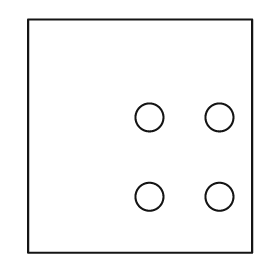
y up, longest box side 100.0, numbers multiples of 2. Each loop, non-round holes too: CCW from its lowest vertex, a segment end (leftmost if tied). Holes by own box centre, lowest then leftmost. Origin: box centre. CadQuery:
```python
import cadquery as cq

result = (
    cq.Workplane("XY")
    .moveTo(-48.0, -50.0)
    .lineTo(48.0, -50.0)
    .lineTo(48.0, 50.0)
    .lineTo(-48.0, 50.0)
    .close()
    .moveTo(4.0, -26.0)
    .circle(6.0)
    .moveTo(34.0, -26.0)
    .circle(6.0)
    .moveTo(4.0, 8.0)
    .circle(6.0)
    .moveTo(34.0, 8.0)
    .circle(6.0)
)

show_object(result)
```